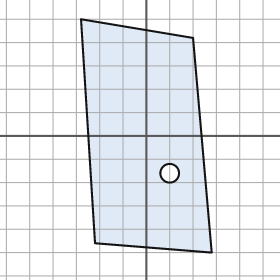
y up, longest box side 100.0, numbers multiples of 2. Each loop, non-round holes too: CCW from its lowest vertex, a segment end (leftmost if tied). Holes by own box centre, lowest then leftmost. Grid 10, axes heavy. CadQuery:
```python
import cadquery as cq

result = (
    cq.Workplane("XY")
    .moveTo(28.0, -50.0)
    .lineTo(20.0, 42.0)
    .lineTo(-28.0, 50.0)
    .lineTo(-22.0, -46.0)
    .close()
    .moveTo(10.0, -16.0)
    .circle(4.0)
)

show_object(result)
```